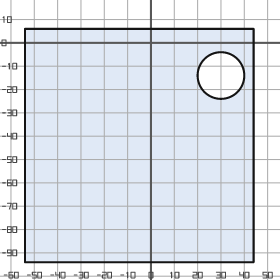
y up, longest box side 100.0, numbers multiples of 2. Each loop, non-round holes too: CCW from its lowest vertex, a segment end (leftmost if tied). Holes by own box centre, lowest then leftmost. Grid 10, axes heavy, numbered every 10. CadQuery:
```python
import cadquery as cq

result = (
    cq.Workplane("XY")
    .moveTo(-54.0, -94.0)
    .lineTo(44.0, -94.0)
    .lineTo(44.0, 6.0)
    .lineTo(-54.0, 6.0)
    .close()
    .moveTo(30.0, -14.0)
    .circle(10.0)
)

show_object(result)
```